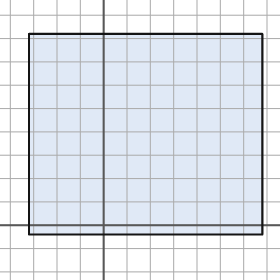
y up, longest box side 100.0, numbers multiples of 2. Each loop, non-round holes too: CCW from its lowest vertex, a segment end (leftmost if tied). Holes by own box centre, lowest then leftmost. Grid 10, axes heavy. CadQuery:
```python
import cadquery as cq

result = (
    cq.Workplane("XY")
    .moveTo(-32.0, -4.0)
    .lineTo(68.0, -4.0)
    .lineTo(68.0, 82.0)
    .lineTo(-32.0, 82.0)
    .close()
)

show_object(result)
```